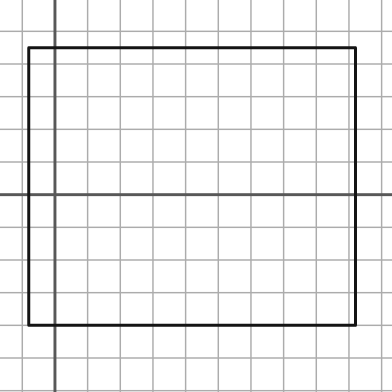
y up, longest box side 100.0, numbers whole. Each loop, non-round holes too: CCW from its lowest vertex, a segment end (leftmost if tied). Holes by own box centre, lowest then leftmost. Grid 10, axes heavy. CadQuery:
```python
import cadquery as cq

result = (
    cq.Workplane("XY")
    .moveTo(-8.0, -40.0)
    .lineTo(92.0, -40.0)
    .lineTo(92.0, 45.0)
    .lineTo(-8.0, 45.0)
    .close()
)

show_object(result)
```